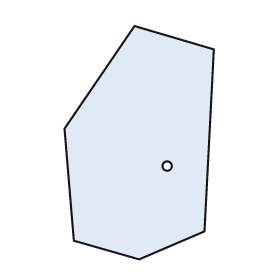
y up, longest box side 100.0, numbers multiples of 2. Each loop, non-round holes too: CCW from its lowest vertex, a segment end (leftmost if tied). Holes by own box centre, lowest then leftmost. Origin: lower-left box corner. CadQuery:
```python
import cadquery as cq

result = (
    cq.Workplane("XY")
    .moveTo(32.0, 0.0)
    .lineTo(60.0, 12.0)
    .lineTo(64.0, 90.0)
    .lineTo(30.0, 100.0)
    .lineTo(0.0, 56.0)
    .lineTo(4.0, 8.0)
    .close()
    .moveTo(44.0, 40.0)
    .circle(2.0)
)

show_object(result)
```